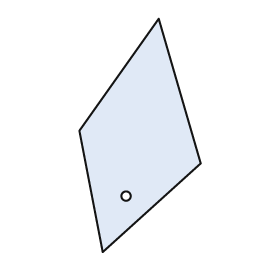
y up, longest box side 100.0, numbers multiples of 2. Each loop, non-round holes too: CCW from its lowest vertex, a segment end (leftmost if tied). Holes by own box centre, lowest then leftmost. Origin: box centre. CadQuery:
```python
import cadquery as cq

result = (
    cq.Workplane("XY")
    .moveTo(-16.0, -50.0)
    .lineTo(26.0, -12.0)
    .lineTo(8.0, 50.0)
    .lineTo(-26.0, 2.0)
    .close()
    .moveTo(-6.0, -26.0)
    .circle(2.0)
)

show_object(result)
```